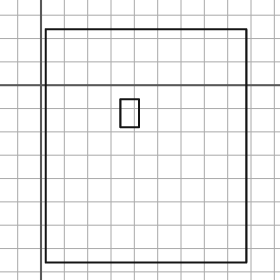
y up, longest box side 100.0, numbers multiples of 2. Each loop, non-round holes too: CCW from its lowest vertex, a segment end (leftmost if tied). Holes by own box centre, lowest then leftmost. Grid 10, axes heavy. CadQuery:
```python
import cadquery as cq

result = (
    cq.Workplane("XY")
    .moveTo(2.0, -76.0)
    .lineTo(88.0, -76.0)
    .lineTo(88.0, 24.0)
    .lineTo(2.0, 24.0)
    .close()
    .moveTo(34.0, -18.0)
    .lineTo(42.0, -18.0)
    .lineTo(42.0, -6.0)
    .lineTo(34.0, -6.0)
    .close()
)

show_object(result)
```